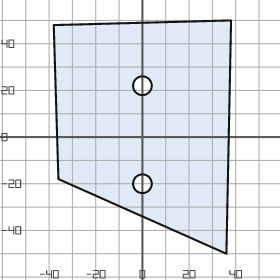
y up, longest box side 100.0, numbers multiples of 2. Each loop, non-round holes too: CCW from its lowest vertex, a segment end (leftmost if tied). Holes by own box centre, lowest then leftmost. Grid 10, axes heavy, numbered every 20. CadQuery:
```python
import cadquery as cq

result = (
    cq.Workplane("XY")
    .moveTo(36.0, -50.0)
    .lineTo(38.0, 50.0)
    .lineTo(-38.0, 48.0)
    .lineTo(-36.0, -18.0)
    .close()
    .moveTo(0.0, -20.0)
    .circle(4.0)
    .moveTo(0.0, 22.0)
    .circle(4.0)
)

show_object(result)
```